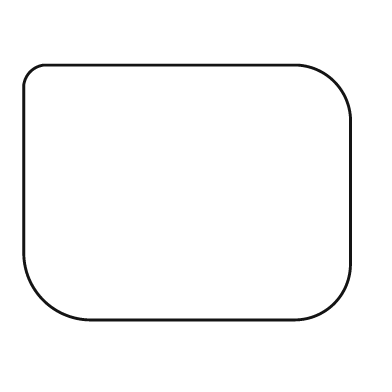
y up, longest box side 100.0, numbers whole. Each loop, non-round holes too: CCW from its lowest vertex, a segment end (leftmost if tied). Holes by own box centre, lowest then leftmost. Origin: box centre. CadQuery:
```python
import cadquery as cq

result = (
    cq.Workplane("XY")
    .moveTo(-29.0, -39.0)
    .lineTo(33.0, -39.0)
    .threePointArc((45.0, -34.0), (50.0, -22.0))
    .lineTo(50.0, 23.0)
    .threePointArc((45.0, 34.0), (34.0, 39.0))
    .lineTo(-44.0, 39.0)
    .threePointArc((-48.0, 37.0), (-50.0, 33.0))
    .lineTo(-50.0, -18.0)
    .threePointArc((-44.0, -33.0), (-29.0, -39.0))
    .close()
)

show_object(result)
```